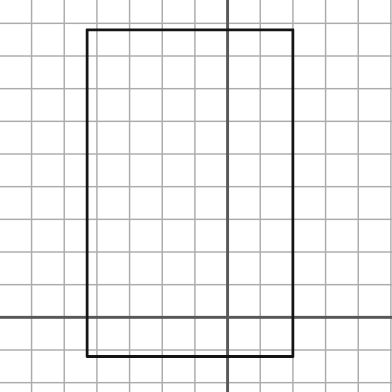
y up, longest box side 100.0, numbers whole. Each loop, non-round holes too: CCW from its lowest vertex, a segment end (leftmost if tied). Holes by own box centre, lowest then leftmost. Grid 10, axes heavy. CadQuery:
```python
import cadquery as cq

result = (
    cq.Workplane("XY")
    .moveTo(-43.0, -12.0)
    .lineTo(20.0, -12.0)
    .lineTo(20.0, 88.0)
    .lineTo(-43.0, 88.0)
    .close()
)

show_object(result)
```